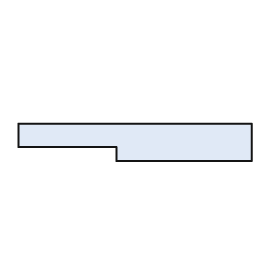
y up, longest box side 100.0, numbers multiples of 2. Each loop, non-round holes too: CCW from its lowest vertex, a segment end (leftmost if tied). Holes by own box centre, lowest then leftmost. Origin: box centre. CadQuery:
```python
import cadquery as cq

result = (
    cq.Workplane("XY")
    .moveTo(-8.0, -8.0)
    .lineTo(50.0, -8.0)
    .lineTo(50.0, 8.0)
    .lineTo(-50.0, 8.0)
    .lineTo(-50.0, -2.0)
    .lineTo(-8.0, -2.0)
    .close()
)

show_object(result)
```